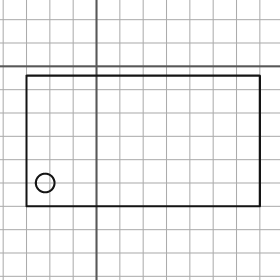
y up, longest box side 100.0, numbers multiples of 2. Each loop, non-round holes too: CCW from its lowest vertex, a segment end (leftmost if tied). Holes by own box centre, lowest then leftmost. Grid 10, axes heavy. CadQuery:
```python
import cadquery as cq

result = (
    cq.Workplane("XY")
    .moveTo(-30.0, -60.0)
    .lineTo(70.0, -60.0)
    .lineTo(70.0, -4.0)
    .lineTo(-30.0, -4.0)
    .close()
    .moveTo(-22.0, -50.0)
    .circle(4.0)
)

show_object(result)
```